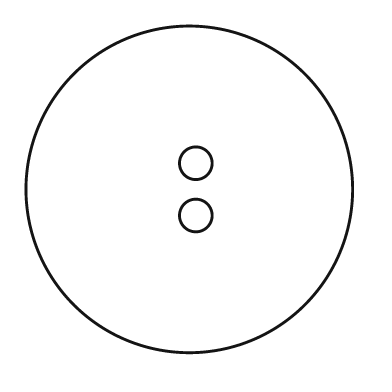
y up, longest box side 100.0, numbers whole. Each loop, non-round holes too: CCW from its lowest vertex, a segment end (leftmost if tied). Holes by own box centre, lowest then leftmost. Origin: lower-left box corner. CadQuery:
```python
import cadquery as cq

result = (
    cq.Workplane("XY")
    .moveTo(50.0, 50.0)
    .circle(50.0)
    .moveTo(52.0, 42.0)
    .circle(5.0)
    .moveTo(52.0, 58.0)
    .circle(5.0)
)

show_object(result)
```